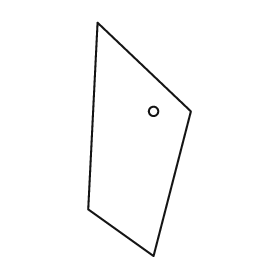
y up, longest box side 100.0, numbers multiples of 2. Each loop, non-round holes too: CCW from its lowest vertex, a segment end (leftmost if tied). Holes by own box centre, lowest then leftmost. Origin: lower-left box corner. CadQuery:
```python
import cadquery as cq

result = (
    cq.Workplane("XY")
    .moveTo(28.0, 0.0)
    .lineTo(44.0, 62.0)
    .lineTo(4.0, 100.0)
    .lineTo(0.0, 20.0)
    .close()
    .moveTo(28.0, 62.0)
    .circle(2.0)
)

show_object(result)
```